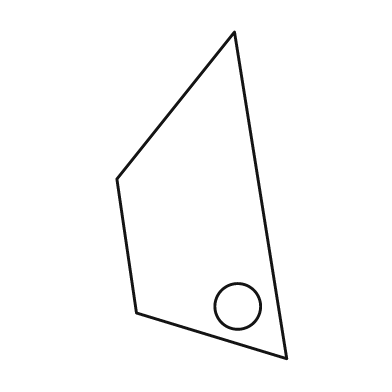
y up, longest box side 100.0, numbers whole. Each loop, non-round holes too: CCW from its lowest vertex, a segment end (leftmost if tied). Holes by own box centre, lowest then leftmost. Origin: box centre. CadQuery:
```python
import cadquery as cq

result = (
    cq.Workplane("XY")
    .moveTo(26.0, -50.0)
    .lineTo(10.0, 50.0)
    .lineTo(-26.0, 5.0)
    .lineTo(-20.0, -36.0)
    .close()
    .moveTo(11.0, -34.0)
    .circle(7.0)
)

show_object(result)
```